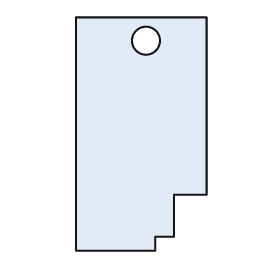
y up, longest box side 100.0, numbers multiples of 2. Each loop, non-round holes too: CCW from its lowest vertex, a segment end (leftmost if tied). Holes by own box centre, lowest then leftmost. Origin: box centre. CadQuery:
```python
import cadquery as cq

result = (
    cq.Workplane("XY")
    .moveTo(-28.0, -50.0)
    .lineTo(6.0, -50.0)
    .lineTo(6.0, -44.0)
    .lineTo(14.0, -44.0)
    .lineTo(14.0, -26.0)
    .lineTo(28.0, -26.0)
    .lineTo(28.0, 50.0)
    .lineTo(-28.0, 50.0)
    .close()
    .moveTo(2.0, 40.0)
    .circle(6.0)
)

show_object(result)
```